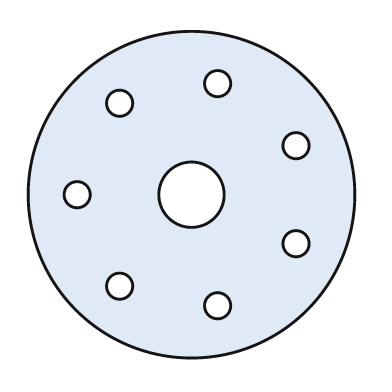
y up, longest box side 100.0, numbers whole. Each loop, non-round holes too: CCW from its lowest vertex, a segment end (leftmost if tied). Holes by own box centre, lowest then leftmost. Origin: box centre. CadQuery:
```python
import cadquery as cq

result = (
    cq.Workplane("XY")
    .moveTo(0.0, 0.0)
    .circle(50.0)
    .moveTo(8.0, -34.0)
    .circle(4.0)
    .moveTo(-22.0, -28.0)
    .circle(4.0)
    .moveTo(32.0, -15.0)
    .circle(4.0)
    .moveTo(-35.0, 0.0)
    .circle(4.0)
    .moveTo(0.0, 0.0)
    .circle(10.0)
    .moveTo(32.0, 15.0)
    .circle(4.0)
    .moveTo(-22.0, 28.0)
    .circle(4.0)
    .moveTo(8.0, 34.0)
    .circle(4.0)
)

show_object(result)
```